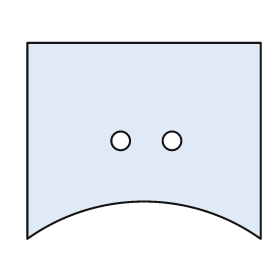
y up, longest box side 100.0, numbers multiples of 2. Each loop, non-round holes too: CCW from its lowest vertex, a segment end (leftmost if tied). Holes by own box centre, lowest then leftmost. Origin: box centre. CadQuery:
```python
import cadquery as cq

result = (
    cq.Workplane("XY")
    .moveTo(-50.0, -42.0)
    .threePointArc((0.0, -26.0), (50.0, -42.0))
    .lineTo(50.0, 42.0)
    .lineTo(-50.0, 42.0)
    .close()
    .moveTo(-10.0, 0.0)
    .circle(4.0)
    .moveTo(12.0, 0.0)
    .circle(4.0)
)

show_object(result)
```